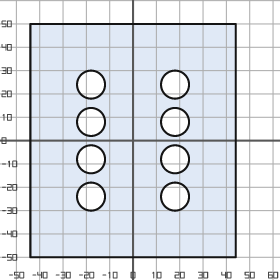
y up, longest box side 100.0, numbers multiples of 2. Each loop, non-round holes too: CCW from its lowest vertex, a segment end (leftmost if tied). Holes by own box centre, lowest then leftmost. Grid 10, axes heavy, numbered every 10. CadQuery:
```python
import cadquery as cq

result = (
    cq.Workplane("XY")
    .moveTo(-44.0, -50.0)
    .lineTo(44.0, -50.0)
    .lineTo(44.0, 50.0)
    .lineTo(-44.0, 50.0)
    .close()
    .moveTo(-18.0, -24.0)
    .circle(6.0)
    .moveTo(18.0, -24.0)
    .circle(6.0)
    .moveTo(-18.0, -8.0)
    .circle(6.0)
    .moveTo(18.0, -8.0)
    .circle(6.0)
    .moveTo(-18.0, 8.0)
    .circle(6.0)
    .moveTo(18.0, 8.0)
    .circle(6.0)
    .moveTo(-18.0, 24.0)
    .circle(6.0)
    .moveTo(18.0, 24.0)
    .circle(6.0)
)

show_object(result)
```